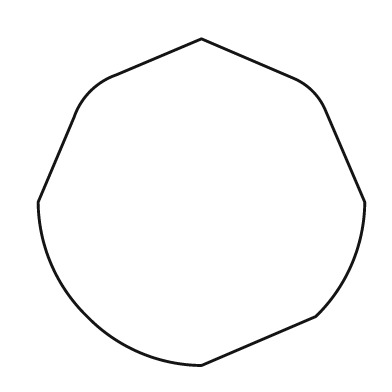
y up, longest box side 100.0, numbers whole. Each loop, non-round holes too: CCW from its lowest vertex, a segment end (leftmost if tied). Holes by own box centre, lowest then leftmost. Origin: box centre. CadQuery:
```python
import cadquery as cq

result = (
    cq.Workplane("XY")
    .moveTo(0.0, -50.0)
    .lineTo(35.0, -35.0)
    .threePointArc((46.0, -19.0), (50.0, 0.0))
    .lineTo(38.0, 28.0)
    .threePointArc((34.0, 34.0), (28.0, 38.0))
    .lineTo(0.0, 50.0)
    .lineTo(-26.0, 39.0)
    .threePointArc((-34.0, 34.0), (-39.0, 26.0))
    .lineTo(-50.0, 0.0)
    .threePointArc((-46.0, -19.0), (-35.0, -35.0))
    .threePointArc((-19.0, -46.0), (0.0, -50.0))
    .close()
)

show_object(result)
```